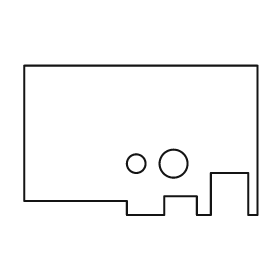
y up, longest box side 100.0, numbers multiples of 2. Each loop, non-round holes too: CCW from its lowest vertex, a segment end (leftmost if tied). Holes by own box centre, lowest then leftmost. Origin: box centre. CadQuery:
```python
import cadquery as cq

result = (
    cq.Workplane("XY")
    .moveTo(-6.0, -32.0)
    .lineTo(10.0, -32.0)
    .lineTo(10.0, -24.0)
    .lineTo(24.0, -24.0)
    .lineTo(24.0, -32.0)
    .lineTo(30.0, -32.0)
    .lineTo(30.0, -14.0)
    .lineTo(46.0, -14.0)
    .lineTo(46.0, -32.0)
    .lineTo(50.0, -32.0)
    .lineTo(50.0, 32.0)
    .lineTo(-50.0, 32.0)
    .lineTo(-50.0, -26.0)
    .lineTo(-6.0, -26.0)
    .close()
    .moveTo(-2.0, -10.0)
    .circle(4.0)
    .moveTo(14.0, -10.0)
    .circle(6.0)
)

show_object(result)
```